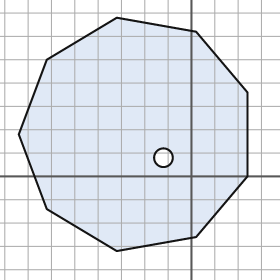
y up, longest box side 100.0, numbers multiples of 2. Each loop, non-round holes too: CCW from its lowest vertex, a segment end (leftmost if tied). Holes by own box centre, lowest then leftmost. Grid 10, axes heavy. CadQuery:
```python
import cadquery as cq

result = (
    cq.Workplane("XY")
    .moveTo(-32.0, -32.0)
    .lineTo(2.0, -26.0)
    .lineTo(24.0, 0.0)
    .lineTo(24.0, 36.0)
    .lineTo(2.0, 62.0)
    .lineTo(-32.0, 68.0)
    .lineTo(-62.0, 50.0)
    .lineTo(-74.0, 18.0)
    .lineTo(-62.0, -14.0)
    .close()
    .moveTo(-12.0, 8.0)
    .circle(4.0)
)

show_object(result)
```